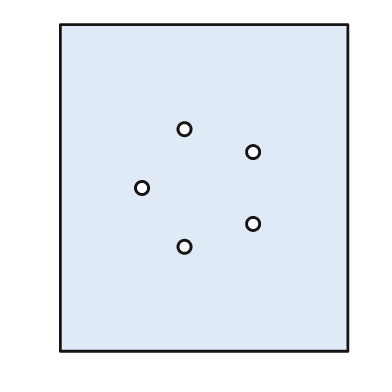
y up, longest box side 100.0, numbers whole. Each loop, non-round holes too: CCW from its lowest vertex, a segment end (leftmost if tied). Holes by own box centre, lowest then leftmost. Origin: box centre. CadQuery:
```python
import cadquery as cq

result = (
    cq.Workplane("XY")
    .moveTo(-44.0, -50.0)
    .lineTo(44.0, -50.0)
    .lineTo(44.0, 50.0)
    .lineTo(-44.0, 50.0)
    .close()
    .moveTo(-6.0, -18.0)
    .circle(2.0)
    .moveTo(15.0, -11.0)
    .circle(2.0)
    .moveTo(-19.0, 0.0)
    .circle(2.0)
    .moveTo(15.0, 11.0)
    .circle(2.0)
    .moveTo(-6.0, 18.0)
    .circle(2.0)
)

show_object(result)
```